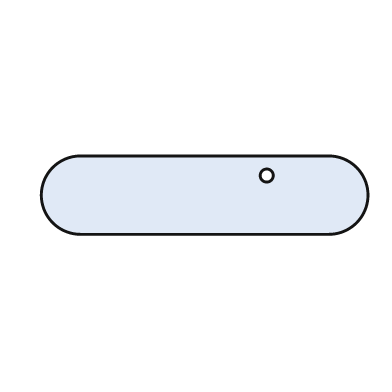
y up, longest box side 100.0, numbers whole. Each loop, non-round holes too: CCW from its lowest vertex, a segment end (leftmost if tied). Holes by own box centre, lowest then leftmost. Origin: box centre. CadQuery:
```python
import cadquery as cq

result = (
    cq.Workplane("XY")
    .moveTo(-38.0, -12.0)
    .lineTo(38.0, -12.0)
    .threePointArc((50.0, 0.0), (38.0, 12.0))
    .lineTo(-38.0, 12.0)
    .threePointArc((-50.0, 0.0), (-38.0, -12.0))
    .close()
    .moveTo(19.0, 6.0)
    .circle(2.0)
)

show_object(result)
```